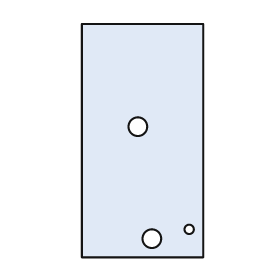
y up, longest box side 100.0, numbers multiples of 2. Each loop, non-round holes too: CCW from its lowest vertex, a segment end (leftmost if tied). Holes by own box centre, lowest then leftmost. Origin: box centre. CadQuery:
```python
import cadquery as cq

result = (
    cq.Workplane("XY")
    .moveTo(-26.0, -50.0)
    .lineTo(26.0, -50.0)
    .lineTo(26.0, 50.0)
    .lineTo(-26.0, 50.0)
    .close()
    .moveTo(4.0, -42.0)
    .circle(4.0)
    .moveTo(20.0, -38.0)
    .circle(2.0)
    .moveTo(-2.0, 6.0)
    .circle(4.0)
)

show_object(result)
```